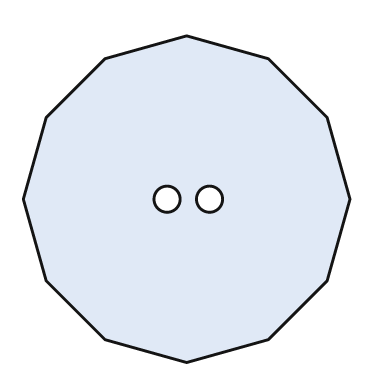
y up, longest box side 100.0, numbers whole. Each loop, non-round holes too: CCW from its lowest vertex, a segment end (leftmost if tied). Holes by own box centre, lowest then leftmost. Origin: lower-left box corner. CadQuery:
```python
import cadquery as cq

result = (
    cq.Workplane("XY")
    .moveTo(50.0, 0.0)
    .lineTo(75.0, 7.0)
    .lineTo(93.0, 25.0)
    .lineTo(100.0, 50.0)
    .lineTo(93.0, 75.0)
    .lineTo(75.0, 93.0)
    .lineTo(50.0, 100.0)
    .lineTo(25.0, 93.0)
    .lineTo(7.0, 75.0)
    .lineTo(0.0, 50.0)
    .lineTo(7.0, 25.0)
    .lineTo(25.0, 7.0)
    .close()
    .moveTo(44.0, 50.0)
    .circle(4.0)
    .moveTo(57.0, 50.0)
    .circle(4.0)
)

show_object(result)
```